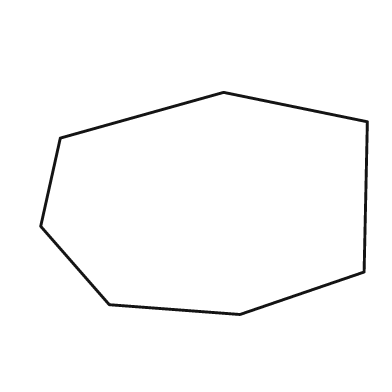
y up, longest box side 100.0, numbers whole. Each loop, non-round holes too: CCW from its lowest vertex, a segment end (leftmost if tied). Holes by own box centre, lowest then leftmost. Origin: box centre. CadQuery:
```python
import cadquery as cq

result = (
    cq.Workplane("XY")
    .moveTo(11.0, -34.0)
    .lineTo(49.0, -21.0)
    .lineTo(50.0, 25.0)
    .lineTo(6.0, 34.0)
    .lineTo(-44.0, 20.0)
    .lineTo(-50.0, -7.0)
    .lineTo(-29.0, -31.0)
    .close()
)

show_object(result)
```